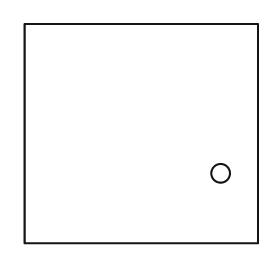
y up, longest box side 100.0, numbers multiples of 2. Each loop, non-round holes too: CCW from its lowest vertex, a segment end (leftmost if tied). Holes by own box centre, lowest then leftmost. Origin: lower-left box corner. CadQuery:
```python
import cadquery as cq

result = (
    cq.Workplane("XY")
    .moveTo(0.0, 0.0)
    .lineTo(100.0, 0.0)
    .lineTo(100.0, 94.0)
    .lineTo(0.0, 94.0)
    .close()
    .moveTo(84.0, 30.0)
    .circle(4.0)
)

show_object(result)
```